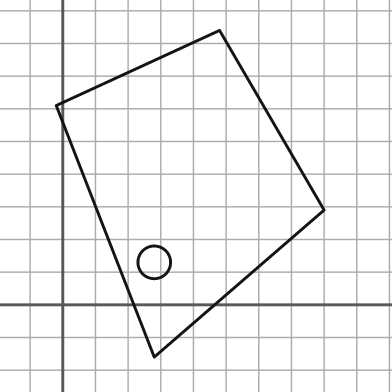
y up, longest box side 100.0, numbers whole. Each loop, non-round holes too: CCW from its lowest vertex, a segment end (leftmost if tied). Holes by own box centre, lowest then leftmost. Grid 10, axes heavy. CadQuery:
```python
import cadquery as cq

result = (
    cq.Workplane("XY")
    .moveTo(28.0, -16.0)
    .lineTo(80.0, 29.0)
    .lineTo(48.0, 84.0)
    .lineTo(-2.0, 61.0)
    .close()
    .moveTo(28.0, 13.0)
    .circle(5.0)
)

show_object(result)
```